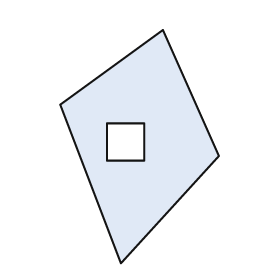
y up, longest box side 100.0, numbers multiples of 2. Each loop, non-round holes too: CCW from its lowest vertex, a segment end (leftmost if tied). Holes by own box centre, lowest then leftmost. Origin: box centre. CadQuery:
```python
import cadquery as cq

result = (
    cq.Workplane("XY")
    .moveTo(-8.0, -50.0)
    .lineTo(34.0, -4.0)
    .lineTo(10.0, 50.0)
    .lineTo(-34.0, 18.0)
    .close()
    .moveTo(-14.0, -6.0)
    .lineTo(2.0, -6.0)
    .lineTo(2.0, 10.0)
    .lineTo(-14.0, 10.0)
    .close()
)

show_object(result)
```